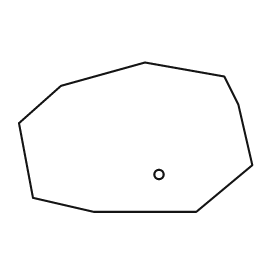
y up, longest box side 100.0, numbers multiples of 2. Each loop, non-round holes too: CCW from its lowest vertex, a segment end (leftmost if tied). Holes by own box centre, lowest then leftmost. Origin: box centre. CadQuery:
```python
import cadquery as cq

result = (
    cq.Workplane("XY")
    .moveTo(-18.0, -32.0)
    .lineTo(26.0, -32.0)
    .lineTo(50.0, -12.0)
    .lineTo(44.0, 14.0)
    .lineTo(38.0, 26.0)
    .lineTo(4.0, 32.0)
    .lineTo(-32.0, 22.0)
    .lineTo(-50.0, 6.0)
    .lineTo(-44.0, -26.0)
    .close()
    .moveTo(10.0, -16.0)
    .circle(2.0)
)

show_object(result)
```